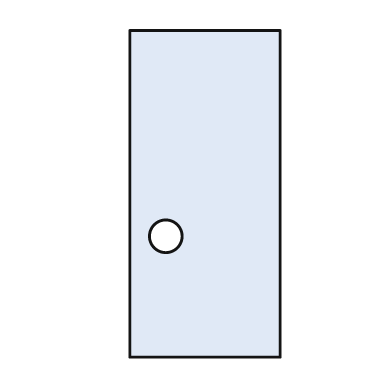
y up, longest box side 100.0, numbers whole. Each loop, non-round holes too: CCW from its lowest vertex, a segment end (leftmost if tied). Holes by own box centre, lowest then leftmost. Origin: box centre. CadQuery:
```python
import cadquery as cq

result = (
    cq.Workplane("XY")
    .moveTo(-23.0, -50.0)
    .lineTo(23.0, -50.0)
    .lineTo(23.0, 50.0)
    .lineTo(-23.0, 50.0)
    .close()
    .moveTo(-12.0, -13.0)
    .circle(5.0)
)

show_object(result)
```